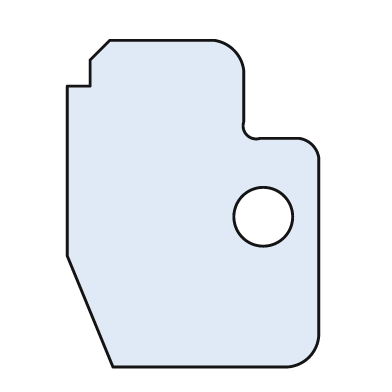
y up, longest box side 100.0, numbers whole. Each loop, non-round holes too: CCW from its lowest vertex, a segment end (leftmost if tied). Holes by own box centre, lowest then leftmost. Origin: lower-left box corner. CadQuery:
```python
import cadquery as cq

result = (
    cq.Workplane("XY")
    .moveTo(14.0, 0.0)
    .lineTo(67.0, 0.0)
    .threePointArc((74.0, 3.0), (77.0, 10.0))
    .lineTo(77.0, 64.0)
    .threePointArc((75.0, 68.0), (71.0, 70.0))
    .lineTo(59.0, 70.0)
    .threePointArc((55.0, 71.0), (54.0, 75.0))
    .lineTo(54.0, 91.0)
    .threePointArc((51.0, 97.0), (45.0, 100.0))
    .lineTo(13.0, 100.0)
    .lineTo(7.0, 94.0)
    .lineTo(7.0, 86.0)
    .lineTo(0.0, 86.0)
    .lineTo(0.0, 34.0)
    .close()
    .moveTo(60.0, 46.0)
    .circle(9.0)
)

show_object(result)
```